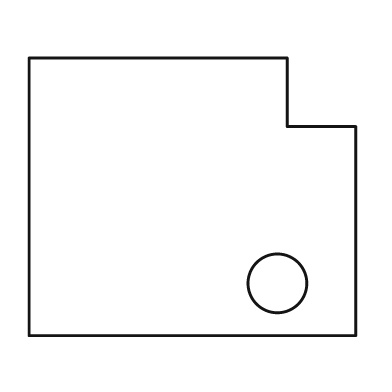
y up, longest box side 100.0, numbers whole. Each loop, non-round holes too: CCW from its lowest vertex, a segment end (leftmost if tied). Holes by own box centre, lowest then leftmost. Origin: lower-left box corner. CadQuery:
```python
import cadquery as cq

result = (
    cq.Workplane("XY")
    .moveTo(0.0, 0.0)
    .lineTo(100.0, 0.0)
    .lineTo(100.0, 64.0)
    .lineTo(79.0, 64.0)
    .lineTo(79.0, 85.0)
    .lineTo(0.0, 85.0)
    .close()
    .moveTo(76.0, 16.0)
    .circle(9.0)
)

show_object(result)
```